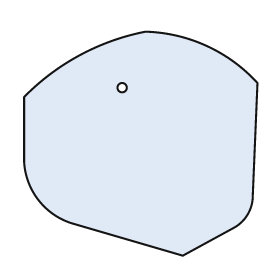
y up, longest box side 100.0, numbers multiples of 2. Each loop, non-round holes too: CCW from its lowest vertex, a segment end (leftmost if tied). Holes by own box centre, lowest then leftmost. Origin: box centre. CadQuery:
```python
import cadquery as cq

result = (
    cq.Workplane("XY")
    .moveTo(18.0, -48.0)
    .lineTo(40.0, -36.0)
    .threePointArc((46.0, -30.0), (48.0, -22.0))
    .lineTo(50.0, 26.0)
    .threePointArc((28.0, 42.0), (2.0, 48.0))
    .threePointArc((-26.0, 38.0), (-50.0, 20.0))
    .lineTo(-50.0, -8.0)
    .threePointArc((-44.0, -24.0), (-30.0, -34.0))
    .close()
    .moveTo(-8.0, 24.0)
    .circle(2.0)
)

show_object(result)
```